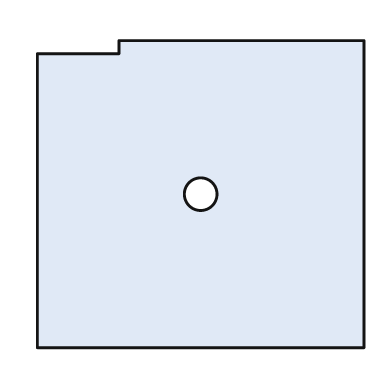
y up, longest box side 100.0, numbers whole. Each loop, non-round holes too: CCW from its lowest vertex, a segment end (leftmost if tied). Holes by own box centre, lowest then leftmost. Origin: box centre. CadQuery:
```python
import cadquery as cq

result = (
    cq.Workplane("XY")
    .moveTo(-50.0, -47.0)
    .lineTo(50.0, -47.0)
    .lineTo(50.0, 47.0)
    .lineTo(-25.0, 47.0)
    .lineTo(-25.0, 43.0)
    .lineTo(-50.0, 43.0)
    .close()
    .moveTo(0.0, 0.0)
    .circle(5.0)
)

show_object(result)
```